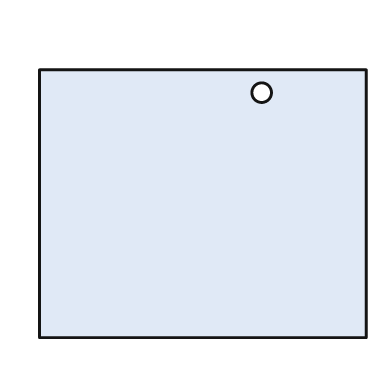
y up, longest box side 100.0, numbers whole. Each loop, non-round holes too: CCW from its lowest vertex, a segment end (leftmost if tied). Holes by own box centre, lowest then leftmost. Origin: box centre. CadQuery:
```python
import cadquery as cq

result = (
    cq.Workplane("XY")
    .moveTo(-50.0, -41.0)
    .lineTo(50.0, -41.0)
    .lineTo(50.0, 41.0)
    .lineTo(-50.0, 41.0)
    .close()
    .moveTo(18.0, 34.0)
    .circle(3.0)
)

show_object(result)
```